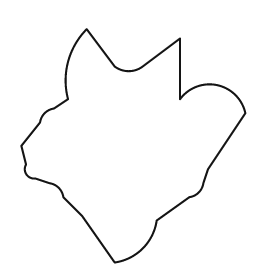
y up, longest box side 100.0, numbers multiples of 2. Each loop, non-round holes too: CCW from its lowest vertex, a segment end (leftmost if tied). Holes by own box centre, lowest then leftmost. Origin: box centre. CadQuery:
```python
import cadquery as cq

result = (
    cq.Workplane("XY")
    .moveTo(-8.0, -50.0)
    .threePointArc((4.0, -44.0), (10.0, -32.0))
    .lineTo(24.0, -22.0)
    .threePointArc((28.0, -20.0), (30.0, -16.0))
    .lineTo(32.0, -10.0)
    .lineTo(48.0, 14.0)
    .threePointArc((36.0, 26.0), (20.0, 20.0))
    .lineTo(20.0, 46.0)
    .lineTo(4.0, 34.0)
    .threePointArc((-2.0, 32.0), (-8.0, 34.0))
    .lineTo(-20.0, 50.0)
    .threePointArc((-28.0, 36.0), (-28.0, 20.0))
    .lineTo(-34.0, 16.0)
    .threePointArc((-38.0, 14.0), (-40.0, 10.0))
    .lineTo(-48.0, 0.0)
    .lineTo(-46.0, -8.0)
    .threePointArc((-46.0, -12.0), (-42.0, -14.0))
    .lineTo(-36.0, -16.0)
    .threePointArc((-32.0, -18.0), (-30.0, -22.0))
    .lineTo(-22.0, -30.0)
    .close()
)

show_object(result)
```